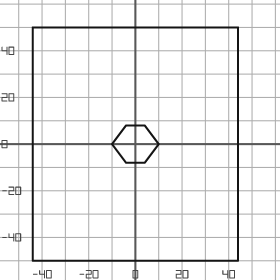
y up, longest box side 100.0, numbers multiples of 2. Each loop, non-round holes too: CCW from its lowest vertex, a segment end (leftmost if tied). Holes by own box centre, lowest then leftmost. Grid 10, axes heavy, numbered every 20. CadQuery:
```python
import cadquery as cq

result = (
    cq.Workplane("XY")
    .moveTo(-44.0, -50.0)
    .lineTo(44.0, -50.0)
    .lineTo(44.0, 50.0)
    .lineTo(-44.0, 50.0)
    .close()
    .moveTo(-4.0, -8.0)
    .lineTo(4.0, -8.0)
    .lineTo(10.0, 0.0)
    .lineTo(4.0, 8.0)
    .lineTo(-4.0, 8.0)
    .lineTo(-10.0, 0.0)
    .close()
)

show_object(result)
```